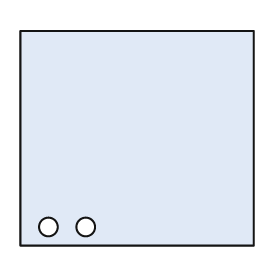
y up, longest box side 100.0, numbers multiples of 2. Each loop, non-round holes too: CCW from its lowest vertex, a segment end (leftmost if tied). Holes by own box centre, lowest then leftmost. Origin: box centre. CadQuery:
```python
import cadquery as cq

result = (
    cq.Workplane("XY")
    .moveTo(-50.0, -46.0)
    .lineTo(50.0, -46.0)
    .lineTo(50.0, 46.0)
    .lineTo(-50.0, 46.0)
    .close()
    .moveTo(-38.0, -38.0)
    .circle(4.0)
    .moveTo(-22.0, -38.0)
    .circle(4.0)
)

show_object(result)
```